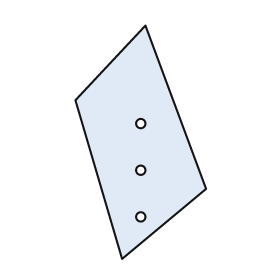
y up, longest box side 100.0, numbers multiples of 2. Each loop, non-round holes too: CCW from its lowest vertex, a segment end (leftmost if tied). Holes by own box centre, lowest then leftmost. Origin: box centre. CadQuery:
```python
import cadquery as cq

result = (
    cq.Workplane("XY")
    .moveTo(-8.0, -50.0)
    .lineTo(28.0, -20.0)
    .lineTo(2.0, 50.0)
    .lineTo(-28.0, 18.0)
    .close()
    .moveTo(0.0, -32.0)
    .circle(2.0)
    .moveTo(0.0, -12.0)
    .circle(2.0)
    .moveTo(0.0, 8.0)
    .circle(2.0)
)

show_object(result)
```